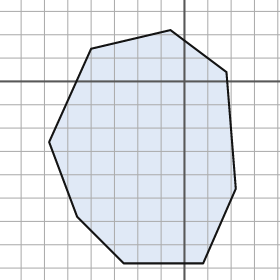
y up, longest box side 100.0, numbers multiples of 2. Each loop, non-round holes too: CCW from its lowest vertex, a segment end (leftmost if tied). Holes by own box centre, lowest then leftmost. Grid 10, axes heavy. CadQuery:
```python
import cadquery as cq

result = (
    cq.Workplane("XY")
    .moveTo(-26.0, -78.0)
    .lineTo(8.0, -78.0)
    .lineTo(22.0, -46.0)
    .lineTo(18.0, 4.0)
    .lineTo(-6.0, 22.0)
    .lineTo(-40.0, 14.0)
    .lineTo(-58.0, -26.0)
    .lineTo(-46.0, -58.0)
    .close()
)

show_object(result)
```